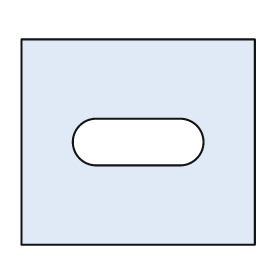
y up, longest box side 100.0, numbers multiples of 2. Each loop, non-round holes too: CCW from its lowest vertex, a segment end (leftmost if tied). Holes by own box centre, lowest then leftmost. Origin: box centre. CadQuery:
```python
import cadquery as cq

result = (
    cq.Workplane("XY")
    .moveTo(-50.0, -44.0)
    .lineTo(50.0, -44.0)
    .lineTo(50.0, 44.0)
    .lineTo(-50.0, 44.0)
    .close()
    .moveTo(-18.0, -10.0)
    .lineTo(18.0, -10.0)
    .threePointArc((28.0, 0.0), (18.0, 10.0))
    .lineTo(-18.0, 10.0)
    .threePointArc((-28.0, 0.0), (-18.0, -10.0))
    .close()
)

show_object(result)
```